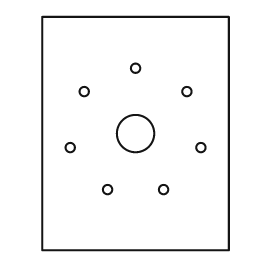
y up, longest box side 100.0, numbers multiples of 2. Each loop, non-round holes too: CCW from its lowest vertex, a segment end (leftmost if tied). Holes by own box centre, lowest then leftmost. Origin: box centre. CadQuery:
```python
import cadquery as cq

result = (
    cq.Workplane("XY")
    .moveTo(-40.0, -50.0)
    .lineTo(40.0, -50.0)
    .lineTo(40.0, 50.0)
    .lineTo(-40.0, 50.0)
    .close()
    .moveTo(-12.0, -24.0)
    .circle(2.0)
    .moveTo(12.0, -24.0)
    .circle(2.0)
    .moveTo(-28.0, -6.0)
    .circle(2.0)
    .moveTo(28.0, -6.0)
    .circle(2.0)
    .moveTo(0.0, 0.0)
    .circle(8.0)
    .moveTo(-22.0, 18.0)
    .circle(2.0)
    .moveTo(22.0, 18.0)
    .circle(2.0)
    .moveTo(0.0, 28.0)
    .circle(2.0)
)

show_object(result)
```